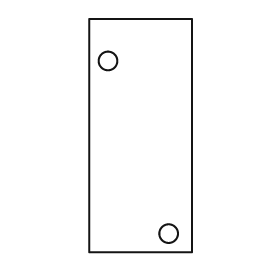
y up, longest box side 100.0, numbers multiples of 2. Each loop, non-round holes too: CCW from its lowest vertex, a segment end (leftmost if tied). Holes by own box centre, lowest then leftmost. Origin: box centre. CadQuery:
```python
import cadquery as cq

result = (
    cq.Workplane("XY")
    .moveTo(-22.0, -50.0)
    .lineTo(22.0, -50.0)
    .lineTo(22.0, 50.0)
    .lineTo(-22.0, 50.0)
    .close()
    .moveTo(12.0, -42.0)
    .circle(4.0)
    .moveTo(-14.0, 32.0)
    .circle(4.0)
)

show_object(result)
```